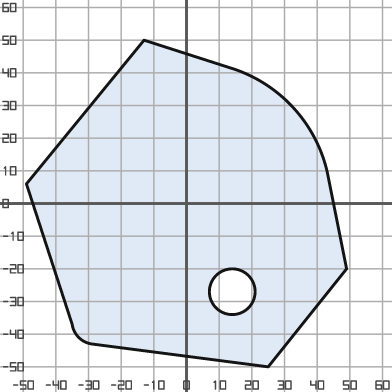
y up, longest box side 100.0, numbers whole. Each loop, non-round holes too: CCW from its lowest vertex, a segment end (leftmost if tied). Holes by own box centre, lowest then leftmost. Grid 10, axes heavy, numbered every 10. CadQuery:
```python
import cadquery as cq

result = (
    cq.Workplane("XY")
    .moveTo(25.0, -50.0)
    .lineTo(49.0, -20.0)
    .lineTo(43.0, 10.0)
    .threePointArc((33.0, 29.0), (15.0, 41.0))
    .lineTo(-13.0, 50.0)
    .lineTo(-49.0, 6.0)
    .lineTo(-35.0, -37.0)
    .threePointArc((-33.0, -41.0), (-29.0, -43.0))
    .close()
    .moveTo(14.0, -27.0)
    .circle(7.0)
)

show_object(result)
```